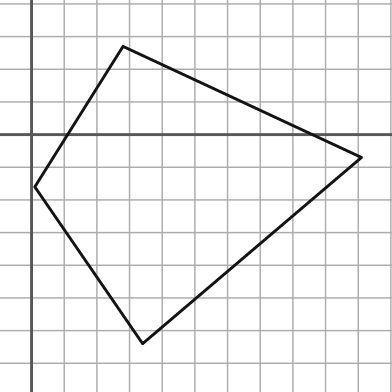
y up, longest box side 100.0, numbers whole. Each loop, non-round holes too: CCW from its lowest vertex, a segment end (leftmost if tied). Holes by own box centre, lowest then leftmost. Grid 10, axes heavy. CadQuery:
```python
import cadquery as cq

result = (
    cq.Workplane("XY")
    .moveTo(34.0, -64.0)
    .lineTo(101.0, -7.0)
    .lineTo(28.0, 27.0)
    .lineTo(1.0, -16.0)
    .close()
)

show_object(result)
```